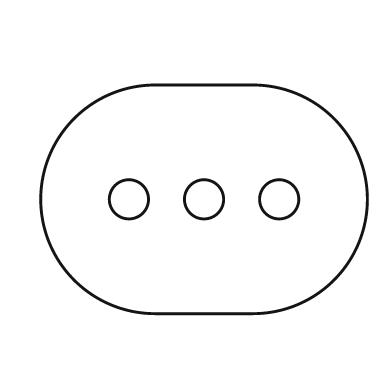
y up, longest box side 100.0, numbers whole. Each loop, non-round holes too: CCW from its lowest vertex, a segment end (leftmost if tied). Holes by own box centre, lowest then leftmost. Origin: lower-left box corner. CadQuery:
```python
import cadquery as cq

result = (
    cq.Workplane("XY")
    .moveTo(35.0, 0.0)
    .lineTo(65.0, 0.0)
    .threePointArc((100.0, 35.0), (65.0, 70.0))
    .lineTo(35.0, 70.0)
    .threePointArc((0.0, 35.0), (35.0, 0.0))
    .close()
    .moveTo(27.0, 35.0)
    .circle(6.0)
    .moveTo(50.0, 35.0)
    .circle(6.0)
    .moveTo(73.0, 35.0)
    .circle(6.0)
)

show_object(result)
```